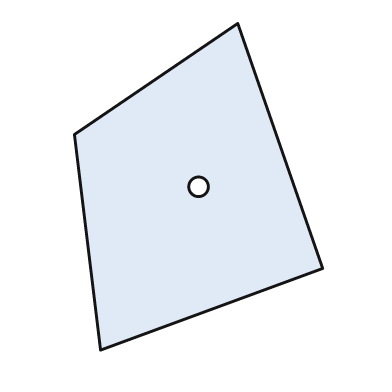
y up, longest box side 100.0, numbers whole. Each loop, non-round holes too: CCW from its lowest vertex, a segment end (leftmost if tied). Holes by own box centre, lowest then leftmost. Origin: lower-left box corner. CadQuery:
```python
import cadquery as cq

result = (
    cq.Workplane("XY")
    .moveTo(8.0, 0.0)
    .lineTo(76.0, 25.0)
    .lineTo(50.0, 100.0)
    .lineTo(0.0, 66.0)
    .close()
    .moveTo(38.0, 50.0)
    .circle(3.0)
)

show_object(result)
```